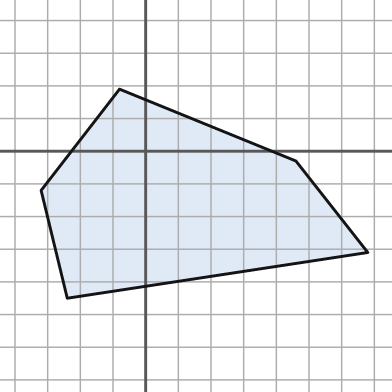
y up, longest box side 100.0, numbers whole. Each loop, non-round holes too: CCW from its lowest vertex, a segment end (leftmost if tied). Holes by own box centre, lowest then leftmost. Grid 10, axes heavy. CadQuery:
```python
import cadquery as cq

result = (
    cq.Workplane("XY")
    .moveTo(-24.0, -45.0)
    .lineTo(68.0, -31.0)
    .lineTo(46.0, -3.0)
    .lineTo(-8.0, 19.0)
    .lineTo(-32.0, -12.0)
    .close()
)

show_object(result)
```